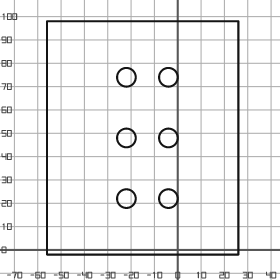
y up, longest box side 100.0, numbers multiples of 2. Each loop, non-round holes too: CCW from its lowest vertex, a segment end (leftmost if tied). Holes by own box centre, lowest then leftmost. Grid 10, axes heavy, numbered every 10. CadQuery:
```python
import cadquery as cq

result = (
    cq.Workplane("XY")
    .moveTo(-56.0, -2.0)
    .lineTo(26.0, -2.0)
    .lineTo(26.0, 98.0)
    .lineTo(-56.0, 98.0)
    .close()
    .moveTo(-22.0, 22.0)
    .circle(4.0)
    .moveTo(-4.0, 22.0)
    .circle(4.0)
    .moveTo(-22.0, 48.0)
    .circle(4.0)
    .moveTo(-4.0, 48.0)
    .circle(4.0)
    .moveTo(-22.0, 74.0)
    .circle(4.0)
    .moveTo(-4.0, 74.0)
    .circle(4.0)
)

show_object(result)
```